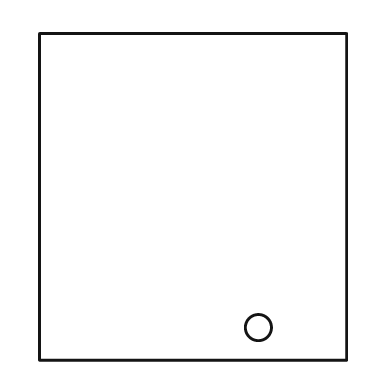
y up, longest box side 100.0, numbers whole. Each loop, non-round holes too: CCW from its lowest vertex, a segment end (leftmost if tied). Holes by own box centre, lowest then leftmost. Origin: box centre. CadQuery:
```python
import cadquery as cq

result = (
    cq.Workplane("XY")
    .moveTo(-47.0, -50.0)
    .lineTo(47.0, -50.0)
    .lineTo(47.0, 50.0)
    .lineTo(-47.0, 50.0)
    .close()
    .moveTo(20.0, -40.0)
    .circle(4.0)
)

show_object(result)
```